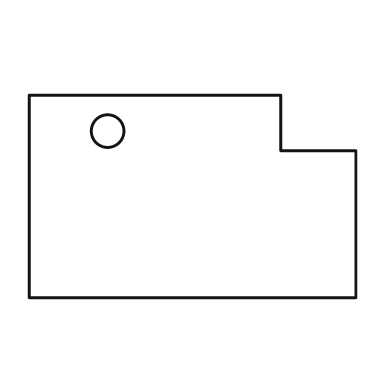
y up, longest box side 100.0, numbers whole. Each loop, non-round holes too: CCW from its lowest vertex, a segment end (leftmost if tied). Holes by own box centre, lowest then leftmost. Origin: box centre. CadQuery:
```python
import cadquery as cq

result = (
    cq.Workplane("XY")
    .moveTo(-50.0, -31.0)
    .lineTo(50.0, -31.0)
    .lineTo(50.0, 14.0)
    .lineTo(27.0, 14.0)
    .lineTo(27.0, 31.0)
    .lineTo(-50.0, 31.0)
    .close()
    .moveTo(-26.0, 20.0)
    .circle(5.0)
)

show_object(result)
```